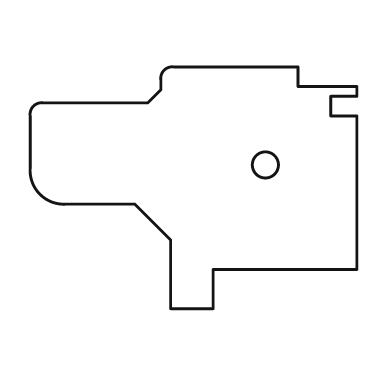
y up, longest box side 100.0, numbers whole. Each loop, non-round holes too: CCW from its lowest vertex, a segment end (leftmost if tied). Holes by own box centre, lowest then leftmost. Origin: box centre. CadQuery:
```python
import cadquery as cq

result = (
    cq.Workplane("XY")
    .moveTo(-7.0, -37.0)
    .lineTo(6.0, -37.0)
    .lineTo(6.0, -25.0)
    .lineTo(50.0, -25.0)
    .lineTo(50.0, 22.0)
    .lineTo(42.0, 22.0)
    .lineTo(42.0, 28.0)
    .lineTo(50.0, 28.0)
    .lineTo(50.0, 31.0)
    .lineTo(32.0, 31.0)
    .lineTo(32.0, 37.0)
    .lineTo(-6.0, 37.0)
    .threePointArc((-9.0, 36.0), (-10.0, 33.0))
    .lineTo(-10.0, 30.0)
    .lineTo(-14.0, 26.0)
    .lineTo(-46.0, 26.0)
    .threePointArc((-49.0, 25.0), (-50.0, 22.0))
    .lineTo(-50.0, 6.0)
    .threePointArc((-47.0, -2.0), (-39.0, -5.0))
    .lineTo(-18.0, -5.0)
    .lineTo(-7.0, -16.0)
    .close()
    .moveTo(22.0, 7.0)
    .circle(4.0)
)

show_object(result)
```